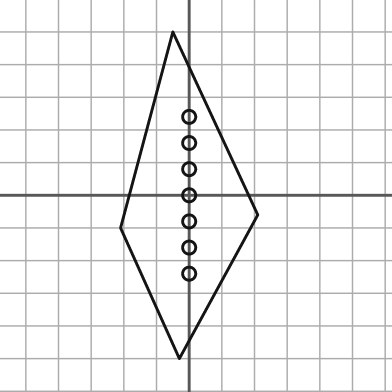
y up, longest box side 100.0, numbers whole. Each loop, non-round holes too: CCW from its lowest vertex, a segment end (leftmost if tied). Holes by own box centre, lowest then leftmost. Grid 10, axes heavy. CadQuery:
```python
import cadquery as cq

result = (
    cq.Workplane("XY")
    .moveTo(-3.0, -50.0)
    .lineTo(21.0, -6.0)
    .lineTo(-5.0, 50.0)
    .lineTo(-21.0, -10.0)
    .close()
    .moveTo(0.0, -24.0)
    .circle(2.0)
    .moveTo(0.0, -16.0)
    .circle(2.0)
    .moveTo(0.0, -8.0)
    .circle(2.0)
    .moveTo(0.0, 0.0)
    .circle(2.0)
    .moveTo(0.0, 8.0)
    .circle(2.0)
    .moveTo(0.0, 16.0)
    .circle(2.0)
    .moveTo(0.0, 24.0)
    .circle(2.0)
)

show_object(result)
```